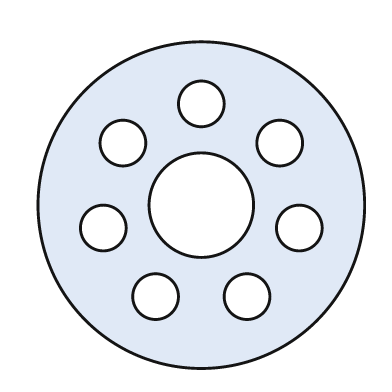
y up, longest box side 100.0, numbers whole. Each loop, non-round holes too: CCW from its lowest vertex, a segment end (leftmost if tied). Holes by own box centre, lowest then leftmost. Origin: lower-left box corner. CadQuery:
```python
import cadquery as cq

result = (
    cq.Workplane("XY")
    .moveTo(50.0, 50.0)
    .circle(50.0)
    .moveTo(36.0, 22.0)
    .circle(7.0)
    .moveTo(64.0, 22.0)
    .circle(7.0)
    .moveTo(20.0, 43.0)
    .circle(7.0)
    .moveTo(80.0, 43.0)
    .circle(7.0)
    .moveTo(50.0, 50.0)
    .circle(16.0)
    .moveTo(26.0, 69.0)
    .circle(7.0)
    .moveTo(74.0, 69.0)
    .circle(7.0)
    .moveTo(50.0, 81.0)
    .circle(7.0)
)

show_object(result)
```